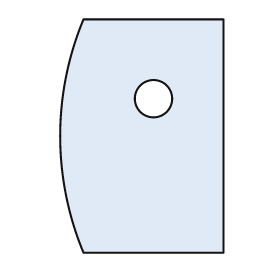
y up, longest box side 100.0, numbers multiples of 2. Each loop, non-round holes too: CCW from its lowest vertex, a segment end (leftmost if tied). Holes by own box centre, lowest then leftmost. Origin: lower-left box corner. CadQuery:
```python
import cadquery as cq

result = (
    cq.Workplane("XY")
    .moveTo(10.0, 0.0)
    .lineTo(70.0, 0.0)
    .lineTo(70.0, 100.0)
    .lineTo(10.0, 100.0)
    .threePointArc((0.0, 50.0), (10.0, 0.0))
    .close()
    .moveTo(40.0, 66.0)
    .circle(8.0)
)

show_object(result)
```